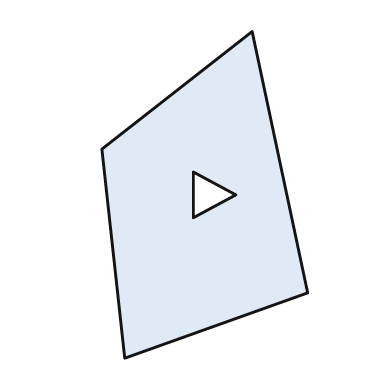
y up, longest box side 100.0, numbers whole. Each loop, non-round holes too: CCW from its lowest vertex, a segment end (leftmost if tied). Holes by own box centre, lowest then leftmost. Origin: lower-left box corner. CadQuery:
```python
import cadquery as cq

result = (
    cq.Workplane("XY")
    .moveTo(7.0, 0.0)
    .lineTo(63.0, 20.0)
    .lineTo(46.0, 100.0)
    .lineTo(0.0, 64.0)
    .close()
    .moveTo(28.0, 43.0)
    .lineTo(41.0, 50.0)
    .lineTo(28.0, 57.0)
    .close()
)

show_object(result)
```